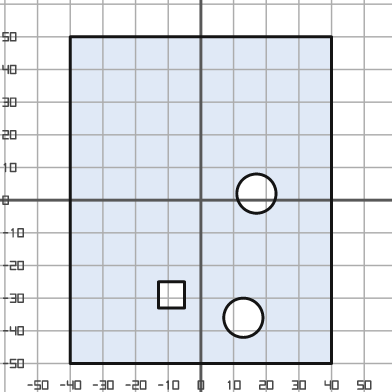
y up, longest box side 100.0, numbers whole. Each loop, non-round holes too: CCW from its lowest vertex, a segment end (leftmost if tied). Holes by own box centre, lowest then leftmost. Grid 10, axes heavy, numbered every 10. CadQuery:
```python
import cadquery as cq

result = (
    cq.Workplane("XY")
    .moveTo(-40.0, -50.0)
    .lineTo(40.0, -50.0)
    .lineTo(40.0, 50.0)
    .lineTo(-40.0, 50.0)
    .close()
    .moveTo(13.0, -36.0)
    .circle(6.0)
    .moveTo(-13.0, -33.0)
    .lineTo(-5.0, -33.0)
    .lineTo(-5.0, -25.0)
    .lineTo(-13.0, -25.0)
    .close()
    .moveTo(17.0, 2.0)
    .circle(6.0)
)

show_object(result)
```